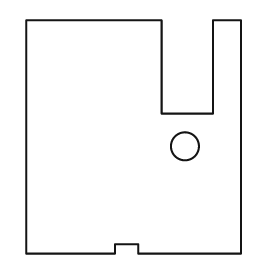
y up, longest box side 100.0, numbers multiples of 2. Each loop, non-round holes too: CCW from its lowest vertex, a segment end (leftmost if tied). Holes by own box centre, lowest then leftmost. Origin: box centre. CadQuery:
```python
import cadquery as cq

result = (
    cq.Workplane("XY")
    .moveTo(-46.0, -50.0)
    .lineTo(-8.0, -50.0)
    .lineTo(-8.0, -46.0)
    .lineTo(2.0, -46.0)
    .lineTo(2.0, -50.0)
    .lineTo(46.0, -50.0)
    .lineTo(46.0, 50.0)
    .lineTo(34.0, 50.0)
    .lineTo(34.0, 10.0)
    .lineTo(12.0, 10.0)
    .lineTo(12.0, 50.0)
    .lineTo(-46.0, 50.0)
    .close()
    .moveTo(22.0, -4.0)
    .circle(6.0)
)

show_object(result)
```